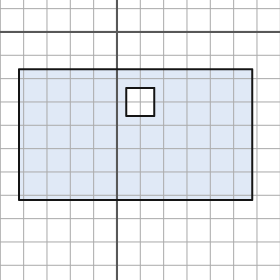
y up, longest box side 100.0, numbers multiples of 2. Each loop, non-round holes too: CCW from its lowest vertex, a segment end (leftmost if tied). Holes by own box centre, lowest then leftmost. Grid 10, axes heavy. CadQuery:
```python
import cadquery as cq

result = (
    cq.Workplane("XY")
    .moveTo(-42.0, -72.0)
    .lineTo(58.0, -72.0)
    .lineTo(58.0, -16.0)
    .lineTo(-42.0, -16.0)
    .close()
    .moveTo(4.0, -36.0)
    .lineTo(16.0, -36.0)
    .lineTo(16.0, -24.0)
    .lineTo(4.0, -24.0)
    .close()
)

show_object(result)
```